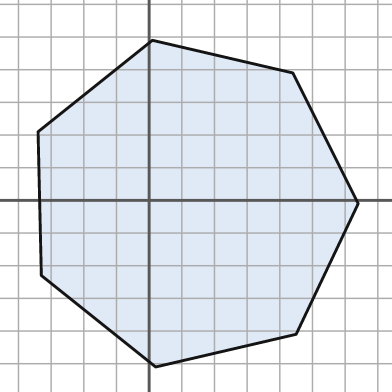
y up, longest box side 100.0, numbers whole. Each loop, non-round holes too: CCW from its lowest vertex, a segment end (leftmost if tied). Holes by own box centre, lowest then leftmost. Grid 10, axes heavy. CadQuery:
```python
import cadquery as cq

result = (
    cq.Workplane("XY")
    .moveTo(2.0, -51.0)
    .lineTo(45.0, -41.0)
    .lineTo(64.0, -1.0)
    .lineTo(44.0, 39.0)
    .lineTo(1.0, 49.0)
    .lineTo(-34.0, 21.0)
    .lineTo(-33.0, -23.0)
    .close()
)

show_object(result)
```